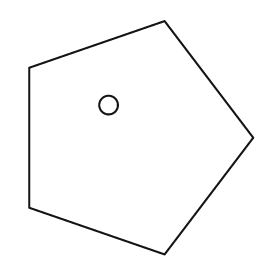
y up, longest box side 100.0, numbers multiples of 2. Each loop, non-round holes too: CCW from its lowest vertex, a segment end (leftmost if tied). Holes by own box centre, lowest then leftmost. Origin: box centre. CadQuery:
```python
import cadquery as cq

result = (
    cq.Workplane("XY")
    .moveTo(10.0, -50.0)
    .lineTo(48.0, 0.0)
    .lineTo(10.0, 50.0)
    .lineTo(-48.0, 30.0)
    .lineTo(-48.0, -30.0)
    .close()
    .moveTo(-14.0, 14.0)
    .circle(4.0)
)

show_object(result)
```